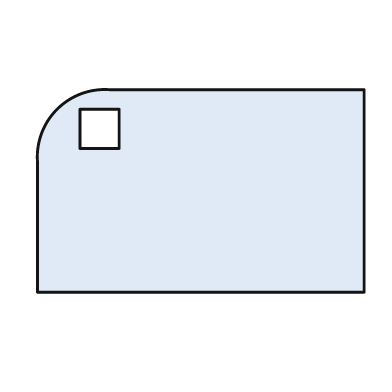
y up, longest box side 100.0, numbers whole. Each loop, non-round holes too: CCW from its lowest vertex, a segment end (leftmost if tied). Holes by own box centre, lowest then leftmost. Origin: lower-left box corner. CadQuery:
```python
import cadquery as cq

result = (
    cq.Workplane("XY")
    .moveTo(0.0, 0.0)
    .lineTo(100.0, 0.0)
    .lineTo(100.0, 62.0)
    .lineTo(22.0, 62.0)
    .threePointArc((6.0, 56.0), (0.0, 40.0))
    .close()
    .moveTo(13.0, 44.0)
    .lineTo(25.0, 44.0)
    .lineTo(25.0, 56.0)
    .lineTo(13.0, 56.0)
    .close()
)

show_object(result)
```